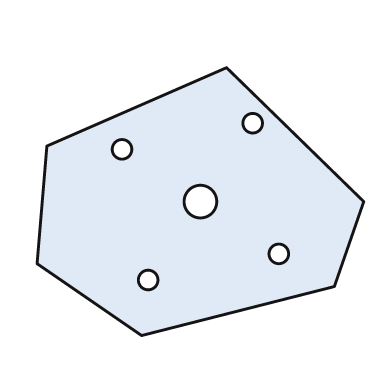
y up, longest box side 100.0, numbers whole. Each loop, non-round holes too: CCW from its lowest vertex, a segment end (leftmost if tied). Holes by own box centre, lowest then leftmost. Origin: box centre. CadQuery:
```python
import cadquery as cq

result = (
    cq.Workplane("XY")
    .moveTo(-18.0, -41.0)
    .lineTo(41.0, -26.0)
    .lineTo(50.0, 0.0)
    .lineTo(8.0, 41.0)
    .lineTo(-47.0, 17.0)
    .lineTo(-50.0, -19.0)
    .close()
    .moveTo(-16.0, -24.0)
    .circle(3.0)
    .moveTo(24.0, -16.0)
    .circle(3.0)
    .moveTo(0.0, 0.0)
    .circle(5.0)
    .moveTo(-24.0, 16.0)
    .circle(3.0)
    .moveTo(16.0, 24.0)
    .circle(3.0)
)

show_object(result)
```